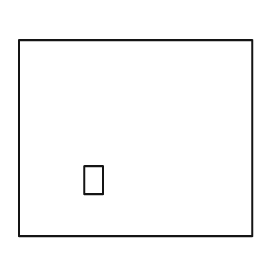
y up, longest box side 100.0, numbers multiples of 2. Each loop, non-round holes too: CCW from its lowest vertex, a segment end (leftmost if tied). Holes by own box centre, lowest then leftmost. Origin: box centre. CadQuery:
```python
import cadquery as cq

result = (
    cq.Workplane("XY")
    .moveTo(-50.0, -42.0)
    .lineTo(50.0, -42.0)
    .lineTo(50.0, 42.0)
    .lineTo(-50.0, 42.0)
    .close()
    .moveTo(-22.0, -24.0)
    .lineTo(-14.0, -24.0)
    .lineTo(-14.0, -12.0)
    .lineTo(-22.0, -12.0)
    .close()
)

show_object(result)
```